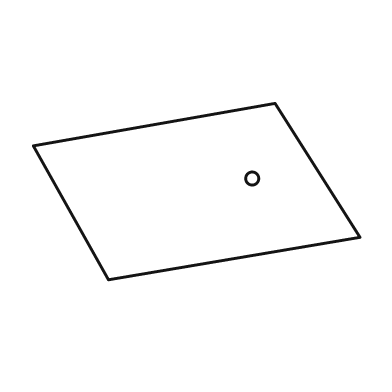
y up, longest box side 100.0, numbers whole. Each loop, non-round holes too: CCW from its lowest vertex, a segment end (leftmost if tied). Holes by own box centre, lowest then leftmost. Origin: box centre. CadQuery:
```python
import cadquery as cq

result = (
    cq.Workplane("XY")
    .moveTo(-27.0, -27.0)
    .lineTo(50.0, -14.0)
    .lineTo(24.0, 27.0)
    .lineTo(-50.0, 14.0)
    .close()
    .moveTo(17.0, 4.0)
    .circle(2.0)
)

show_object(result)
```